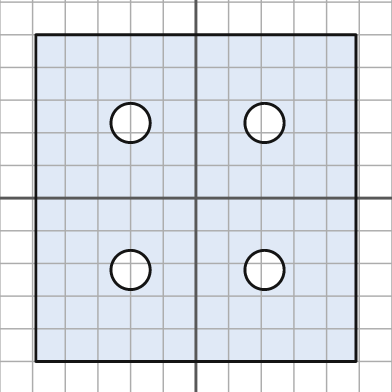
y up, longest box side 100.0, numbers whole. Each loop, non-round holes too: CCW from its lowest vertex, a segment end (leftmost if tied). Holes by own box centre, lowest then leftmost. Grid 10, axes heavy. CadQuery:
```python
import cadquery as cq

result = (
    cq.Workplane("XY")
    .moveTo(-49.0, -50.0)
    .lineTo(49.0, -50.0)
    .lineTo(49.0, 50.0)
    .lineTo(-49.0, 50.0)
    .close()
    .moveTo(-20.0, -22.0)
    .circle(6.0)
    .moveTo(21.0, -22.0)
    .circle(6.0)
    .moveTo(-20.0, 23.0)
    .circle(6.0)
    .moveTo(21.0, 23.0)
    .circle(6.0)
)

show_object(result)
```